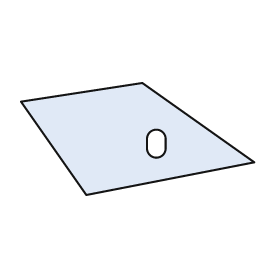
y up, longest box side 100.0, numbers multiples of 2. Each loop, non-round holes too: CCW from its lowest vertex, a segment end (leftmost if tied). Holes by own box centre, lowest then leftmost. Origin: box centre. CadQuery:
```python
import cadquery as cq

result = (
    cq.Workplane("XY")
    .moveTo(-22.0, -24.0)
    .lineTo(50.0, -10.0)
    .lineTo(2.0, 24.0)
    .lineTo(-50.0, 16.0)
    .close()
    .moveTo(4.0, -4.0)
    .threePointArc((8.0, -8.0), (12.0, -4.0))
    .lineTo(12.0, 0.0)
    .threePointArc((8.0, 4.0), (4.0, 0.0))
    .close()
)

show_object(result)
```